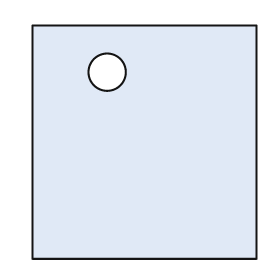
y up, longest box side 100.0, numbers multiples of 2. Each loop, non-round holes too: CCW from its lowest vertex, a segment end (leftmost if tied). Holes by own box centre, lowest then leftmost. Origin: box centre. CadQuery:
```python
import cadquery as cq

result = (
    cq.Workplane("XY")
    .moveTo(-48.0, -50.0)
    .lineTo(48.0, -50.0)
    .lineTo(48.0, 50.0)
    .lineTo(-48.0, 50.0)
    .close()
    .moveTo(-16.0, 30.0)
    .circle(8.0)
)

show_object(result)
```